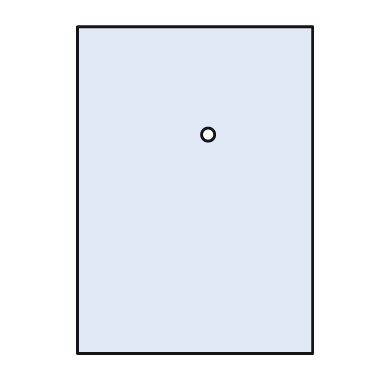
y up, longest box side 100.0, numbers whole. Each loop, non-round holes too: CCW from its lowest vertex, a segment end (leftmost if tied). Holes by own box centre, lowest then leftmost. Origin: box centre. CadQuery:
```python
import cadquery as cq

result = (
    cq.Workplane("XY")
    .moveTo(-36.0, -50.0)
    .lineTo(36.0, -50.0)
    .lineTo(36.0, 50.0)
    .lineTo(-36.0, 50.0)
    .close()
    .moveTo(4.0, 17.0)
    .circle(2.0)
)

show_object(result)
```